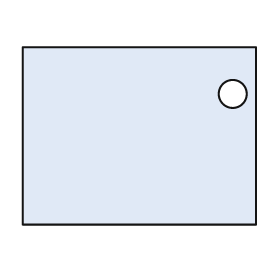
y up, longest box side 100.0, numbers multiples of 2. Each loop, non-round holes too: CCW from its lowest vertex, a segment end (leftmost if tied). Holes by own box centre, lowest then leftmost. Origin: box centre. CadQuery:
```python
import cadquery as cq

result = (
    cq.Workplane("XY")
    .moveTo(-50.0, -38.0)
    .lineTo(50.0, -38.0)
    .lineTo(50.0, 38.0)
    .lineTo(-50.0, 38.0)
    .close()
    .moveTo(40.0, 18.0)
    .circle(6.0)
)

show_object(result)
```